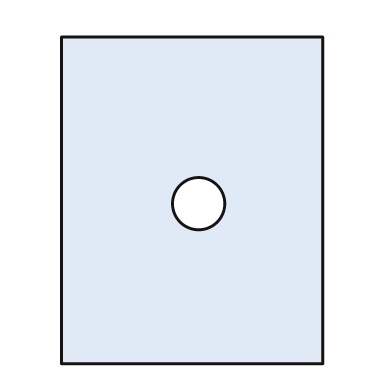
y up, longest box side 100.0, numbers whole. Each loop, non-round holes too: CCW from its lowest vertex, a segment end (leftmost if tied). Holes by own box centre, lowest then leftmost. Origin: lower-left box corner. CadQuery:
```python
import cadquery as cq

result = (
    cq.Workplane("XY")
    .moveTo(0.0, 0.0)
    .lineTo(80.0, 0.0)
    .lineTo(80.0, 100.0)
    .lineTo(0.0, 100.0)
    .close()
    .moveTo(42.0, 49.0)
    .circle(8.0)
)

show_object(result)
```